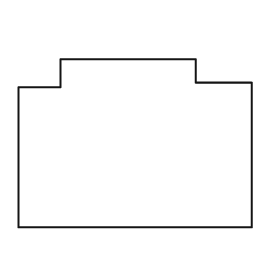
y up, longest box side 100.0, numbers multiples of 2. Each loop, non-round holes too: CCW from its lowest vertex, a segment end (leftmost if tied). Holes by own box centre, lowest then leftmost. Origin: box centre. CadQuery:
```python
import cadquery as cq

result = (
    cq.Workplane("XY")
    .moveTo(-50.0, -36.0)
    .lineTo(50.0, -36.0)
    .lineTo(50.0, 26.0)
    .lineTo(26.0, 26.0)
    .lineTo(26.0, 36.0)
    .lineTo(-32.0, 36.0)
    .lineTo(-32.0, 24.0)
    .lineTo(-50.0, 24.0)
    .close()
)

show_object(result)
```